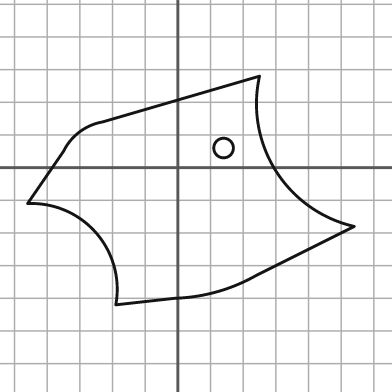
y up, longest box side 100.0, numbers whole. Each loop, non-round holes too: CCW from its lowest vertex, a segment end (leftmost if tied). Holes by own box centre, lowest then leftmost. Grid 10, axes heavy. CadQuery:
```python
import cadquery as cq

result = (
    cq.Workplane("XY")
    .moveTo(-19.0, -42.0)
    .lineTo(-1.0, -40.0)
    .threePointArc((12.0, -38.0), (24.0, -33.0))
    .lineTo(54.0, -18.0)
    .threePointArc((30.0, -1.0), (25.0, 28.0))
    .lineTo(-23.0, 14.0)
    .threePointArc((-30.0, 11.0), (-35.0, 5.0))
    .lineTo(-46.0, -11.0)
    .threePointArc((-25.0, -20.0), (-19.0, -42.0))
    .close()
    .moveTo(14.0, 6.0)
    .circle(3.0)
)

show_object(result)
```